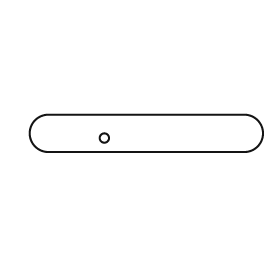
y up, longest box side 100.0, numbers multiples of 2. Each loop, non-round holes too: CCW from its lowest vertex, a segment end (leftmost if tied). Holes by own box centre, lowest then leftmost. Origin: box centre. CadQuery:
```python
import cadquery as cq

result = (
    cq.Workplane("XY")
    .moveTo(-42.0, -8.0)
    .lineTo(42.0, -8.0)
    .threePointArc((50.0, 0.0), (42.0, 8.0))
    .lineTo(-42.0, 8.0)
    .threePointArc((-50.0, 0.0), (-42.0, -8.0))
    .close()
    .moveTo(-18.0, -2.0)
    .circle(2.0)
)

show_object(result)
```